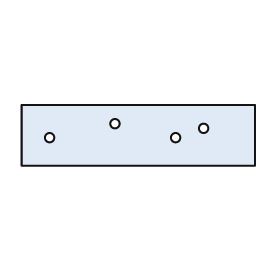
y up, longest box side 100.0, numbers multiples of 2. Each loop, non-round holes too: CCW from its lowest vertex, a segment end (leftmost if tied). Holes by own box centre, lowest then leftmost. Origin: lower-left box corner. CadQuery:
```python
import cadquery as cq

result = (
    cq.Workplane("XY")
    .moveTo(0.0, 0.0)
    .lineTo(100.0, 0.0)
    .lineTo(100.0, 26.0)
    .lineTo(0.0, 26.0)
    .close()
    .moveTo(12.0, 12.0)
    .circle(2.0)
    .moveTo(66.0, 12.0)
    .circle(2.0)
    .moveTo(78.0, 16.0)
    .circle(2.0)
    .moveTo(40.0, 18.0)
    .circle(2.0)
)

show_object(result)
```